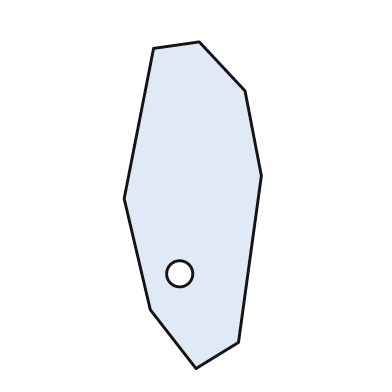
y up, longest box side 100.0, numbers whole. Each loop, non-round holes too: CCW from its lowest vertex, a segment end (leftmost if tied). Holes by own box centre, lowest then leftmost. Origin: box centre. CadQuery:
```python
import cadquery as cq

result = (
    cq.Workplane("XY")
    .moveTo(1.0, -50.0)
    .lineTo(14.0, -42.0)
    .lineTo(21.0, 9.0)
    .lineTo(16.0, 35.0)
    .lineTo(2.0, 50.0)
    .lineTo(-12.0, 48.0)
    .lineTo(-21.0, 2.0)
    .lineTo(-13.0, -32.0)
    .close()
    .moveTo(-4.0, -21.0)
    .circle(4.0)
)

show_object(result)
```